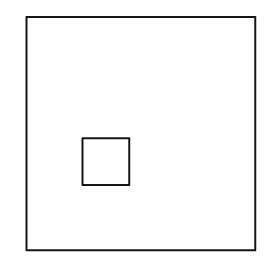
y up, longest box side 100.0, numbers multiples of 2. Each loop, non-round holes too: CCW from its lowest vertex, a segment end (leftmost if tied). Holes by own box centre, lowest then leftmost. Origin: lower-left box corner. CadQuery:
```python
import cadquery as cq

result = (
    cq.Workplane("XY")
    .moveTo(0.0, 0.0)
    .lineTo(98.0, 0.0)
    .lineTo(98.0, 100.0)
    .lineTo(0.0, 100.0)
    .close()
    .moveTo(24.0, 28.0)
    .lineTo(44.0, 28.0)
    .lineTo(44.0, 48.0)
    .lineTo(24.0, 48.0)
    .close()
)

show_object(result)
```